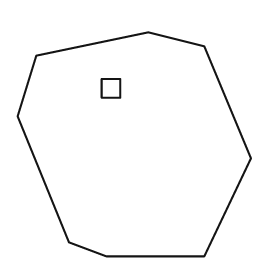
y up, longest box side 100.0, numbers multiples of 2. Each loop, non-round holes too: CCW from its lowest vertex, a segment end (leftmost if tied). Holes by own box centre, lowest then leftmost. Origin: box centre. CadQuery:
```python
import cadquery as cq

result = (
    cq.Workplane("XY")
    .moveTo(-12.0, -48.0)
    .lineTo(30.0, -48.0)
    .lineTo(50.0, -6.0)
    .lineTo(30.0, 42.0)
    .lineTo(6.0, 48.0)
    .lineTo(-42.0, 38.0)
    .lineTo(-50.0, 12.0)
    .lineTo(-28.0, -42.0)
    .close()
    .moveTo(-14.0, 20.0)
    .lineTo(-6.0, 20.0)
    .lineTo(-6.0, 28.0)
    .lineTo(-14.0, 28.0)
    .close()
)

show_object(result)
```